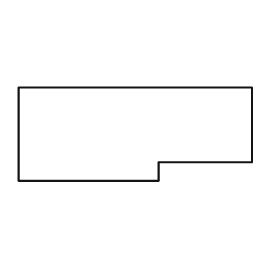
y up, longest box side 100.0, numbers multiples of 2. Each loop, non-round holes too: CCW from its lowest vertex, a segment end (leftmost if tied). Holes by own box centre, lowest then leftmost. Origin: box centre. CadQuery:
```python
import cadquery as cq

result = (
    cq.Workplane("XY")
    .moveTo(-50.0, -20.0)
    .lineTo(10.0, -20.0)
    .lineTo(10.0, -12.0)
    .lineTo(50.0, -12.0)
    .lineTo(50.0, 20.0)
    .lineTo(-50.0, 20.0)
    .close()
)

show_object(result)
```